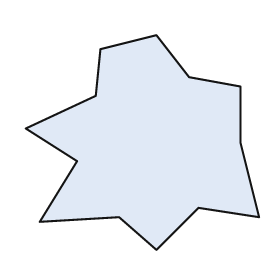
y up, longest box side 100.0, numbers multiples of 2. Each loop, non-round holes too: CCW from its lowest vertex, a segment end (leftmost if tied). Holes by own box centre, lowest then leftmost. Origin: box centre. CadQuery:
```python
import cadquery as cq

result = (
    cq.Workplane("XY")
    .moveTo(6.0, -46.0)
    .lineTo(24.0, -28.0)
    .lineTo(50.0, -32.0)
    .lineTo(42.0, 0.0)
    .lineTo(42.0, 24.0)
    .lineTo(20.0, 28.0)
    .lineTo(6.0, 46.0)
    .lineTo(-18.0, 40.0)
    .lineTo(-20.0, 20.0)
    .lineTo(-50.0, 6.0)
    .lineTo(-28.0, -8.0)
    .lineTo(-44.0, -34.0)
    .lineTo(-10.0, -32.0)
    .close()
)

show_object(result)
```